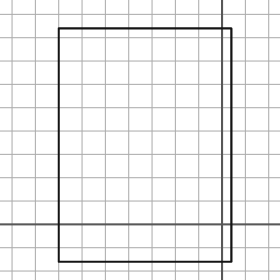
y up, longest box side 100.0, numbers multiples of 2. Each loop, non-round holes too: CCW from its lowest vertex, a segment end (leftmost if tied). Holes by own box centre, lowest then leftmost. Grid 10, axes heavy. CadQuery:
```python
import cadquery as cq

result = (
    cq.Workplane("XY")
    .moveTo(-70.0, -16.0)
    .lineTo(4.0, -16.0)
    .lineTo(4.0, 84.0)
    .lineTo(-70.0, 84.0)
    .close()
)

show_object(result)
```